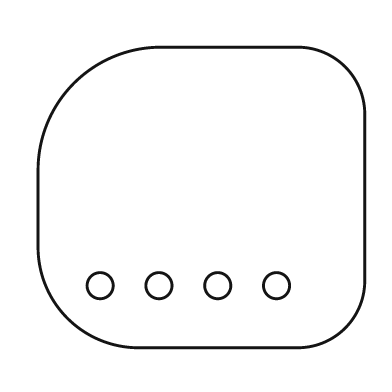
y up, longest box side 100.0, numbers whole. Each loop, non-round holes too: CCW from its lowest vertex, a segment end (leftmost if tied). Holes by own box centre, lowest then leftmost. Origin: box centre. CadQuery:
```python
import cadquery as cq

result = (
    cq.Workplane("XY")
    .moveTo(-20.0, -46.0)
    .lineTo(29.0, -46.0)
    .threePointArc((44.0, -40.0), (50.0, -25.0))
    .lineTo(50.0, 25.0)
    .threePointArc((44.0, 40.0), (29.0, 46.0))
    .lineTo(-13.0, 46.0)
    .threePointArc((-39.0, 35.0), (-50.0, 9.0))
    .lineTo(-50.0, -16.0)
    .threePointArc((-41.0, -37.0), (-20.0, -46.0))
    .close()
    .moveTo(-31.0, -27.0)
    .circle(4.0)
    .moveTo(-13.0, -27.0)
    .circle(4.0)
    .moveTo(5.0, -27.0)
    .circle(4.0)
    .moveTo(23.0, -27.0)
    .circle(4.0)
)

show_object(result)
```